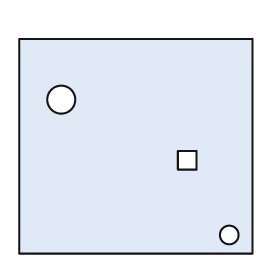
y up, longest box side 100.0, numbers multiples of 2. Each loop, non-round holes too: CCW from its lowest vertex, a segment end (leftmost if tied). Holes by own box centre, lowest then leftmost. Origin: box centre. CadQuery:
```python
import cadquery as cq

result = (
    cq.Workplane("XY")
    .moveTo(-50.0, -46.0)
    .lineTo(50.0, -46.0)
    .lineTo(50.0, 46.0)
    .lineTo(-50.0, 46.0)
    .close()
    .moveTo(40.0, -38.0)
    .circle(4.0)
    .moveTo(18.0, -10.0)
    .lineTo(26.0, -10.0)
    .lineTo(26.0, -2.0)
    .lineTo(18.0, -2.0)
    .close()
    .moveTo(-32.0, 20.0)
    .circle(6.0)
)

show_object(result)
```